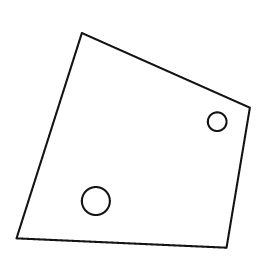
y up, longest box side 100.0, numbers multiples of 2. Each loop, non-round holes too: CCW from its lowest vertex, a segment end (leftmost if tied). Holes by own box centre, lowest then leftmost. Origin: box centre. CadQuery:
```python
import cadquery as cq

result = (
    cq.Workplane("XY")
    .moveTo(40.0, -46.0)
    .lineTo(50.0, 14.0)
    .lineTo(-22.0, 46.0)
    .lineTo(-50.0, -42.0)
    .close()
    .moveTo(-16.0, -26.0)
    .circle(6.0)
    .moveTo(36.0, 8.0)
    .circle(4.0)
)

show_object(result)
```